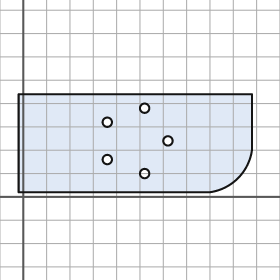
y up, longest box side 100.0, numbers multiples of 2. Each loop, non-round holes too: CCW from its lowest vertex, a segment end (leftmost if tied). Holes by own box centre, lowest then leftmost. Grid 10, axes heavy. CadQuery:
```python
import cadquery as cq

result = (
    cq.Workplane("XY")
    .moveTo(-2.0, 2.0)
    .lineTo(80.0, 2.0)
    .threePointArc((92.0, 8.0), (98.0, 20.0))
    .lineTo(98.0, 44.0)
    .lineTo(-2.0, 44.0)
    .close()
    .moveTo(52.0, 10.0)
    .circle(2.0)
    .moveTo(36.0, 16.0)
    .circle(2.0)
    .moveTo(62.0, 24.0)
    .circle(2.0)
    .moveTo(36.0, 32.0)
    .circle(2.0)
    .moveTo(52.0, 38.0)
    .circle(2.0)
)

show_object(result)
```